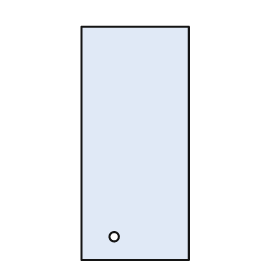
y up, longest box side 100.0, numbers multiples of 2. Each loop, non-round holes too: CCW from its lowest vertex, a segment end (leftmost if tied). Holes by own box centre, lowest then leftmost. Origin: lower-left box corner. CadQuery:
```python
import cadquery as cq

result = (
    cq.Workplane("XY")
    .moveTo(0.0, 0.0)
    .lineTo(46.0, 0.0)
    .lineTo(46.0, 100.0)
    .lineTo(0.0, 100.0)
    .close()
    .moveTo(14.0, 10.0)
    .circle(2.0)
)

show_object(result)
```